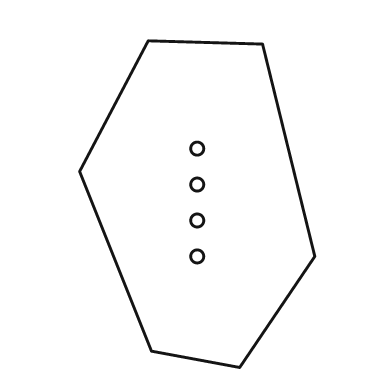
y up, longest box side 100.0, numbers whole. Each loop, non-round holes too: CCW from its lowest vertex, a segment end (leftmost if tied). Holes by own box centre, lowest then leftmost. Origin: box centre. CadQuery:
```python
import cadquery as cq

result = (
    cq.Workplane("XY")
    .moveTo(13.0, -50.0)
    .lineTo(36.0, -16.0)
    .lineTo(20.0, 49.0)
    .lineTo(-15.0, 50.0)
    .lineTo(-36.0, 10.0)
    .lineTo(-14.0, -45.0)
    .close()
    .moveTo(0.0, -16.0)
    .circle(2.0)
    .moveTo(0.0, -5.0)
    .circle(2.0)
    .moveTo(0.0, 6.0)
    .circle(2.0)
    .moveTo(0.0, 17.0)
    .circle(2.0)
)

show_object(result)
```